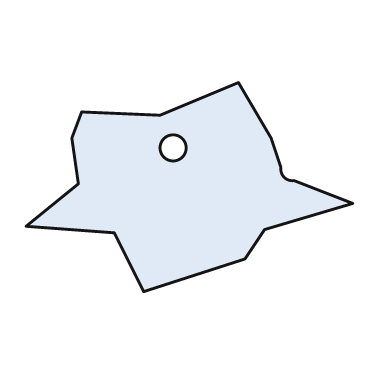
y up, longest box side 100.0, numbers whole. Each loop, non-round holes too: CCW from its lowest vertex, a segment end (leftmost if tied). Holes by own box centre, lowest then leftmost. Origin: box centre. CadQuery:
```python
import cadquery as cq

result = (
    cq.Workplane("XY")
    .moveTo(-14.0, -32.0)
    .lineTo(17.0, -22.0)
    .lineTo(23.0, -13.0)
    .lineTo(50.0, -5.0)
    .lineTo(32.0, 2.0)
    .threePointArc((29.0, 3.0), (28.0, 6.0))
    .lineTo(25.0, 15.0)
    .lineTo(15.0, 32.0)
    .lineTo(-9.0, 22.0)
    .lineTo(-33.0, 23.0)
    .lineTo(-36.0, 15.0)
    .lineTo(-34.0, 1.0)
    .lineTo(-50.0, -12.0)
    .lineTo(-23.0, -14.0)
    .close()
    .moveTo(-5.0, 12.0)
    .circle(4.0)
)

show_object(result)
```